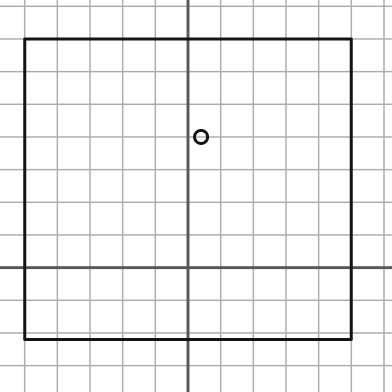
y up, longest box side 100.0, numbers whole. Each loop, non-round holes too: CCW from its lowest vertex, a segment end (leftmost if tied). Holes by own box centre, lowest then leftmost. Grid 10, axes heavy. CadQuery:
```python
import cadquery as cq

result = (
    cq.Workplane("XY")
    .moveTo(-50.0, -22.0)
    .lineTo(50.0, -22.0)
    .lineTo(50.0, 70.0)
    .lineTo(-50.0, 70.0)
    .close()
    .moveTo(4.0, 40.0)
    .circle(2.0)
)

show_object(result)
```